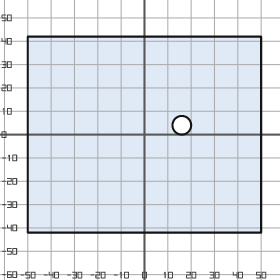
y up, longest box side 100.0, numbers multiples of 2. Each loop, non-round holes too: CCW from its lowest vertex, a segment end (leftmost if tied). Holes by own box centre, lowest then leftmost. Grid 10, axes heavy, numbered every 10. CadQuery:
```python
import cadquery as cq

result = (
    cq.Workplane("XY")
    .moveTo(-50.0, -42.0)
    .lineTo(50.0, -42.0)
    .lineTo(50.0, 42.0)
    .lineTo(-50.0, 42.0)
    .close()
    .moveTo(16.0, 4.0)
    .circle(4.0)
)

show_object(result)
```